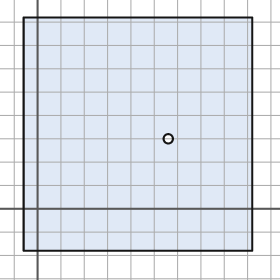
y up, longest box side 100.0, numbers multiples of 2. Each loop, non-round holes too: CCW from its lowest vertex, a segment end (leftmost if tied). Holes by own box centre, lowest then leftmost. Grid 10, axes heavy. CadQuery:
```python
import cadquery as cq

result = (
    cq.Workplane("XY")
    .moveTo(-6.0, -18.0)
    .lineTo(92.0, -18.0)
    .lineTo(92.0, 82.0)
    .lineTo(-6.0, 82.0)
    .close()
    .moveTo(56.0, 30.0)
    .circle(2.0)
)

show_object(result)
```